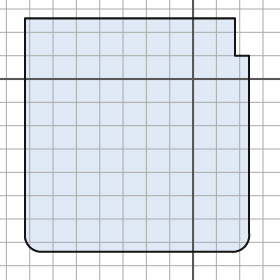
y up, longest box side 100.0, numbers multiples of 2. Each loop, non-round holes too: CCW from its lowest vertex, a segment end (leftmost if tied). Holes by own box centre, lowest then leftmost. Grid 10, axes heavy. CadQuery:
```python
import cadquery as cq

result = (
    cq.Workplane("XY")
    .moveTo(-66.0, -74.0)
    .lineTo(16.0, -74.0)
    .threePointArc((22.0, -72.0), (24.0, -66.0))
    .lineTo(24.0, 10.0)
    .lineTo(18.0, 10.0)
    .lineTo(18.0, 26.0)
    .lineTo(-72.0, 26.0)
    .lineTo(-72.0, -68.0)
    .threePointArc((-70.0, -72.0), (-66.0, -74.0))
    .close()
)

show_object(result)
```